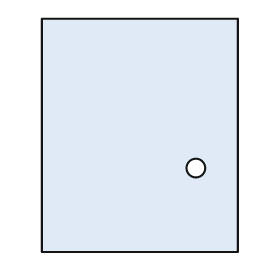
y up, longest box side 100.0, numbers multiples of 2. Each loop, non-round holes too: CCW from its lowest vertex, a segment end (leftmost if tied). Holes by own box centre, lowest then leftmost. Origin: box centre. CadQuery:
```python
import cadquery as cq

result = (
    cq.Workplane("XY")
    .moveTo(-42.0, -50.0)
    .lineTo(42.0, -50.0)
    .lineTo(42.0, 50.0)
    .lineTo(-42.0, 50.0)
    .close()
    .moveTo(24.0, -14.0)
    .circle(4.0)
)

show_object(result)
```